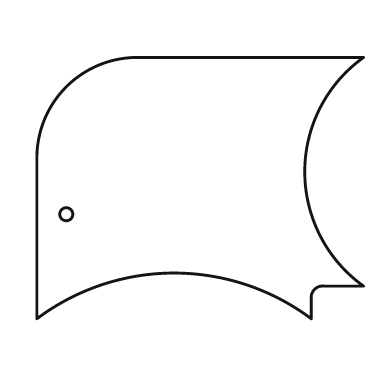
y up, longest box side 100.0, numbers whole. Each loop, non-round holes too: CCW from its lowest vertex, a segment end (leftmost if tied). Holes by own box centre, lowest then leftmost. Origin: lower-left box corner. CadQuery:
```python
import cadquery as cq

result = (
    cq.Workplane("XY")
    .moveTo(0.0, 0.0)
    .threePointArc((42.0, 14.0), (84.0, 0.0))
    .lineTo(84.0, 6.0)
    .threePointArc((85.0, 9.0), (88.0, 10.0))
    .lineTo(100.0, 10.0)
    .threePointArc((82.0, 45.0), (100.0, 80.0))
    .lineTo(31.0, 80.0)
    .threePointArc((9.0, 71.0), (0.0, 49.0))
    .close()
    .moveTo(9.0, 32.0)
    .circle(2.0)
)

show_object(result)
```